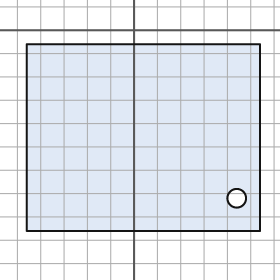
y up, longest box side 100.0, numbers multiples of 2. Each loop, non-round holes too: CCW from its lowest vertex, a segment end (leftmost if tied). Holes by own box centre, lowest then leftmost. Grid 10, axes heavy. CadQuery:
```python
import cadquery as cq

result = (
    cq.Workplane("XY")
    .moveTo(-46.0, -86.0)
    .lineTo(54.0, -86.0)
    .lineTo(54.0, -6.0)
    .lineTo(-46.0, -6.0)
    .close()
    .moveTo(44.0, -72.0)
    .circle(4.0)
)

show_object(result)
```